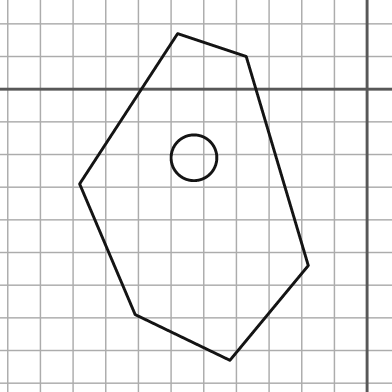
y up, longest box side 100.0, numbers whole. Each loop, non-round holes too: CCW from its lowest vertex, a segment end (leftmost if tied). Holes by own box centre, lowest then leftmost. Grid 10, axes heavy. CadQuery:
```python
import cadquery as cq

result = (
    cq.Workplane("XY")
    .moveTo(-42.0, -83.0)
    .lineTo(-18.0, -54.0)
    .lineTo(-37.0, 10.0)
    .lineTo(-58.0, 17.0)
    .lineTo(-88.0, -29.0)
    .lineTo(-71.0, -69.0)
    .close()
    .moveTo(-53.0, -21.0)
    .circle(7.0)
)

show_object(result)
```